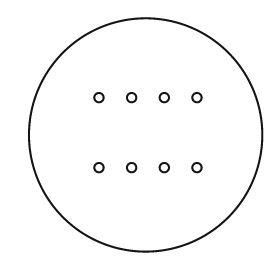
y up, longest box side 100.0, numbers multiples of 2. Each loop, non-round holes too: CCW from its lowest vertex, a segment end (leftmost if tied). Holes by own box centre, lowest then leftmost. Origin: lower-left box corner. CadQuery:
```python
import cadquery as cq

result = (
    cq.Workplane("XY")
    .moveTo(50.0, 50.0)
    .circle(50.0)
    .moveTo(30.0, 36.0)
    .circle(2.0)
    .moveTo(44.0, 36.0)
    .circle(2.0)
    .moveTo(58.0, 36.0)
    .circle(2.0)
    .moveTo(72.0, 36.0)
    .circle(2.0)
    .moveTo(30.0, 66.0)
    .circle(2.0)
    .moveTo(44.0, 66.0)
    .circle(2.0)
    .moveTo(58.0, 66.0)
    .circle(2.0)
    .moveTo(72.0, 66.0)
    .circle(2.0)
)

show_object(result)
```